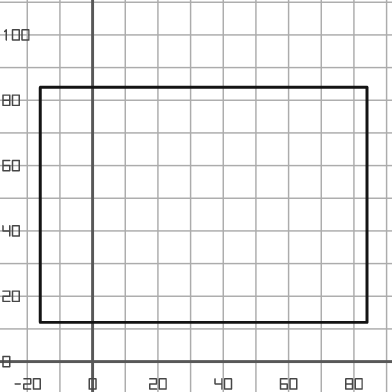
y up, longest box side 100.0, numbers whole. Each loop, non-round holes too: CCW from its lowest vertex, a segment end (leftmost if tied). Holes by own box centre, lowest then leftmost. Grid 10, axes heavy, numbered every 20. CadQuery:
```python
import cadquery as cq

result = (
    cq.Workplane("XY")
    .moveTo(-16.0, 12.0)
    .lineTo(84.0, 12.0)
    .lineTo(84.0, 84.0)
    .lineTo(-16.0, 84.0)
    .close()
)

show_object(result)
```